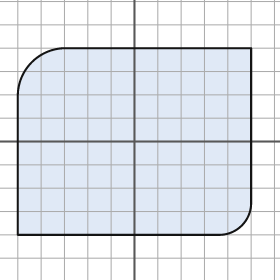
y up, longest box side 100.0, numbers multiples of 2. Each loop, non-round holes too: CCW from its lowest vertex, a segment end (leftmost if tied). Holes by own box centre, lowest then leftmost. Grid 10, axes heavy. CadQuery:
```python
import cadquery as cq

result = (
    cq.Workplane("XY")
    .moveTo(-50.0, -40.0)
    .lineTo(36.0, -40.0)
    .threePointArc((46.0, -36.0), (50.0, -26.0))
    .lineTo(50.0, 40.0)
    .lineTo(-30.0, 40.0)
    .threePointArc((-44.0, 34.0), (-50.0, 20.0))
    .close()
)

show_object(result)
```